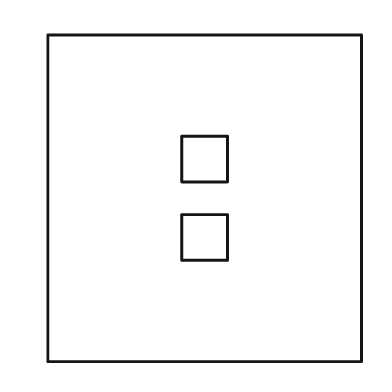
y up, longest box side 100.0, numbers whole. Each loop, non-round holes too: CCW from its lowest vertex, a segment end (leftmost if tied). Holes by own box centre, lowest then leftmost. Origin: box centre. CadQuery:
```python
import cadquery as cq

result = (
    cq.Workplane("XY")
    .moveTo(-48.0, -50.0)
    .lineTo(48.0, -50.0)
    .lineTo(48.0, 50.0)
    .lineTo(-48.0, 50.0)
    .close()
    .moveTo(-7.0, -19.0)
    .lineTo(7.0, -19.0)
    .lineTo(7.0, -5.0)
    .lineTo(-7.0, -5.0)
    .close()
    .moveTo(-7.0, 5.0)
    .lineTo(7.0, 5.0)
    .lineTo(7.0, 19.0)
    .lineTo(-7.0, 19.0)
    .close()
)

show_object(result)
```